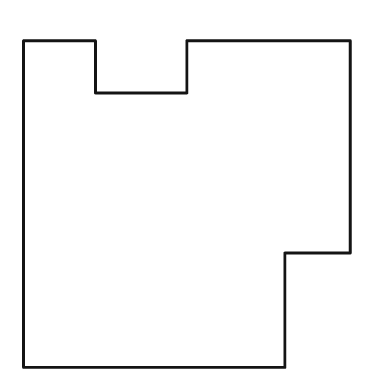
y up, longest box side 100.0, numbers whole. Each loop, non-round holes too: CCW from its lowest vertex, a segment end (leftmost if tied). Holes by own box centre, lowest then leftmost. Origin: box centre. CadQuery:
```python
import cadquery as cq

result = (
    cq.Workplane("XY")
    .moveTo(-50.0, -50.0)
    .lineTo(30.0, -50.0)
    .lineTo(30.0, -15.0)
    .lineTo(50.0, -15.0)
    .lineTo(50.0, 50.0)
    .lineTo(0.0, 50.0)
    .lineTo(0.0, 34.0)
    .lineTo(-28.0, 34.0)
    .lineTo(-28.0, 50.0)
    .lineTo(-50.0, 50.0)
    .close()
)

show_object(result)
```